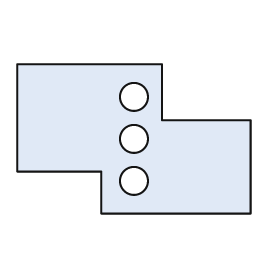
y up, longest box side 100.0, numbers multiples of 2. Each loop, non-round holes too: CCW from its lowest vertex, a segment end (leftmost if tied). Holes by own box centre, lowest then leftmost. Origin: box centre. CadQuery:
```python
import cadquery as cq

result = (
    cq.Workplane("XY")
    .moveTo(-14.0, -32.0)
    .lineTo(50.0, -32.0)
    .lineTo(50.0, 8.0)
    .lineTo(12.0, 8.0)
    .lineTo(12.0, 32.0)
    .lineTo(-50.0, 32.0)
    .lineTo(-50.0, -14.0)
    .lineTo(-14.0, -14.0)
    .close()
    .moveTo(0.0, -18.0)
    .circle(6.0)
    .moveTo(0.0, 0.0)
    .circle(6.0)
    .moveTo(0.0, 18.0)
    .circle(6.0)
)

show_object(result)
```